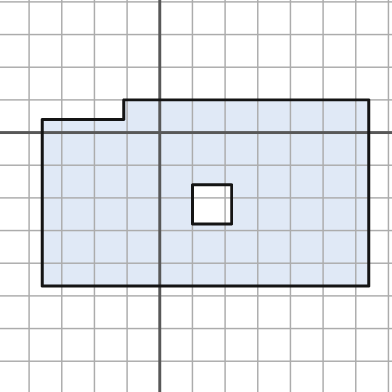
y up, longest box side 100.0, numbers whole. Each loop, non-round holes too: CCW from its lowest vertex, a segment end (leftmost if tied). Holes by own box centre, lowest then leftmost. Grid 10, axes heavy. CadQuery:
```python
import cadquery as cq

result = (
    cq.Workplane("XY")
    .moveTo(-36.0, -47.0)
    .lineTo(64.0, -47.0)
    .lineTo(64.0, 10.0)
    .lineTo(-11.0, 10.0)
    .lineTo(-11.0, 4.0)
    .lineTo(-36.0, 4.0)
    .close()
    .moveTo(10.0, -28.0)
    .lineTo(22.0, -28.0)
    .lineTo(22.0, -16.0)
    .lineTo(10.0, -16.0)
    .close()
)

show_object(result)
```